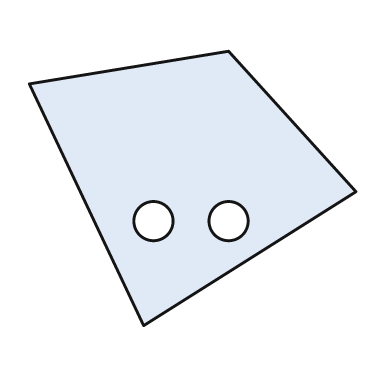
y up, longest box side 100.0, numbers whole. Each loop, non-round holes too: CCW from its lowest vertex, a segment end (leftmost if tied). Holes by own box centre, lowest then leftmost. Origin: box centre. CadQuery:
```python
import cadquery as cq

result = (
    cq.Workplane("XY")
    .moveTo(-15.0, -42.0)
    .lineTo(50.0, -1.0)
    .lineTo(11.0, 42.0)
    .lineTo(-50.0, 32.0)
    .close()
    .moveTo(-12.0, -10.0)
    .circle(6.0)
    .moveTo(11.0, -10.0)
    .circle(6.0)
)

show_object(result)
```